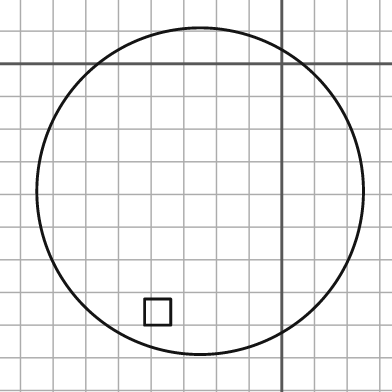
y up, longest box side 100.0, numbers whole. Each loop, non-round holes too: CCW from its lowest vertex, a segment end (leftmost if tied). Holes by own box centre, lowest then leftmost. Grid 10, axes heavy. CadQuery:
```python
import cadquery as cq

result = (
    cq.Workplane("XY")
    .moveTo(-25.0, -39.0)
    .circle(50.0)
    .moveTo(-42.0, -80.0)
    .lineTo(-34.0, -80.0)
    .lineTo(-34.0, -72.0)
    .lineTo(-42.0, -72.0)
    .close()
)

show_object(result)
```